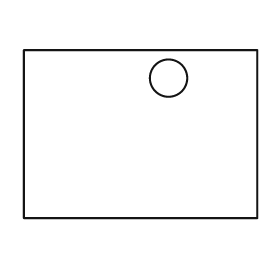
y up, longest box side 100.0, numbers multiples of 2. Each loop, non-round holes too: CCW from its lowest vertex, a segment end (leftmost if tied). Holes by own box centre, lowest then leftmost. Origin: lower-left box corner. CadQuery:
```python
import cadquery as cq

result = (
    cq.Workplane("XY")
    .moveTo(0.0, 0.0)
    .lineTo(100.0, 0.0)
    .lineTo(100.0, 72.0)
    .lineTo(0.0, 72.0)
    .close()
    .moveTo(62.0, 60.0)
    .circle(8.0)
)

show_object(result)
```